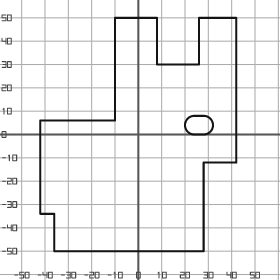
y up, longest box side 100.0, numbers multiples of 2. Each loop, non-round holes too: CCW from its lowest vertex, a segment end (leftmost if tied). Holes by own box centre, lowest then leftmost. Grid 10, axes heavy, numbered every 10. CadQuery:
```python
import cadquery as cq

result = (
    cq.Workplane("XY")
    .moveTo(-36.0, -50.0)
    .lineTo(28.0, -50.0)
    .lineTo(28.0, -12.0)
    .lineTo(42.0, -12.0)
    .lineTo(42.0, 50.0)
    .lineTo(26.0, 50.0)
    .lineTo(26.0, 30.0)
    .lineTo(8.0, 30.0)
    .lineTo(8.0, 50.0)
    .lineTo(-10.0, 50.0)
    .lineTo(-10.0, 6.0)
    .lineTo(-42.0, 6.0)
    .lineTo(-42.0, -34.0)
    .lineTo(-36.0, -34.0)
    .close()
    .moveTo(24.0, 0.0)
    .lineTo(28.0, 0.0)
    .threePointArc((32.0, 4.0), (28.0, 8.0))
    .lineTo(24.0, 8.0)
    .threePointArc((20.0, 4.0), (24.0, 0.0))
    .close()
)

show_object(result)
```